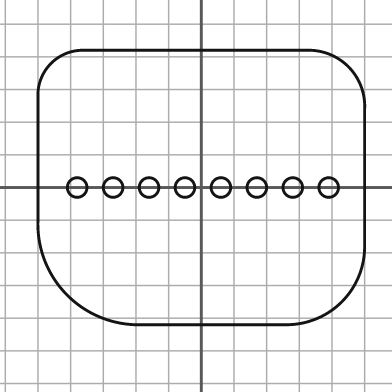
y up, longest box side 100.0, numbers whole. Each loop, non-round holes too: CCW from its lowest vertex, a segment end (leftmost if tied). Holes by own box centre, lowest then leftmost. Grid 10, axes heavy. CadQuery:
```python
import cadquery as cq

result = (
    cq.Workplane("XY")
    .moveTo(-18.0, -42.0)
    .lineTo(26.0, -42.0)
    .threePointArc((43.0, -35.0), (50.0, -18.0))
    .lineTo(50.0, 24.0)
    .threePointArc((45.0, 37.0), (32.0, 42.0))
    .lineTo(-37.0, 42.0)
    .threePointArc((-46.0, 38.0), (-50.0, 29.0))
    .lineTo(-50.0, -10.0)
    .threePointArc((-41.0, -33.0), (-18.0, -42.0))
    .close()
    .moveTo(-38.0, 0.0)
    .circle(3.0)
    .moveTo(-27.0, 0.0)
    .circle(3.0)
    .moveTo(-16.0, 0.0)
    .circle(3.0)
    .moveTo(-5.0, 0.0)
    .circle(3.0)
    .moveTo(6.0, 0.0)
    .circle(3.0)
    .moveTo(17.0, 0.0)
    .circle(3.0)
    .moveTo(28.0, 0.0)
    .circle(3.0)
    .moveTo(39.0, 0.0)
    .circle(3.0)
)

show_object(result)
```